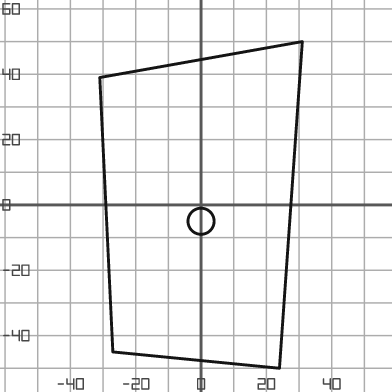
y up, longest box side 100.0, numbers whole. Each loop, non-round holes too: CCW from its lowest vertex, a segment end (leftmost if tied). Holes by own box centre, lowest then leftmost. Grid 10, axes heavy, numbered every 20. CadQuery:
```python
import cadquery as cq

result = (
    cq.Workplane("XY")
    .moveTo(24.0, -50.0)
    .lineTo(31.0, 50.0)
    .lineTo(-31.0, 39.0)
    .lineTo(-27.0, -45.0)
    .close()
    .moveTo(0.0, -5.0)
    .circle(4.0)
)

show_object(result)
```